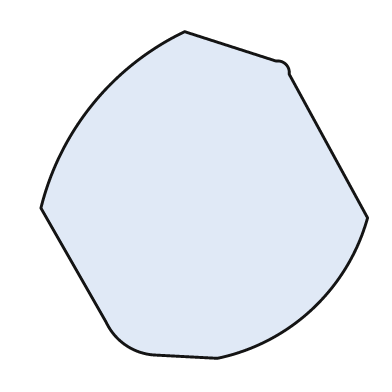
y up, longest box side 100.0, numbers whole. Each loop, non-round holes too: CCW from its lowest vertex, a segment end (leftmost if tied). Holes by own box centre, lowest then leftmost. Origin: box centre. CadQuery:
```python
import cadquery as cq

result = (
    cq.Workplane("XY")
    .moveTo(4.0, -50.0)
    .threePointArc((33.0, -35.0), (50.0, -7.0))
    .lineTo(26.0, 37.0)
    .threePointArc((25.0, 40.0), (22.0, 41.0))
    .lineTo(-6.0, 50.0)
    .threePointArc((-34.0, 28.0), (-50.0, -4.0))
    .lineTo(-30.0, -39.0)
    .threePointArc((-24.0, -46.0), (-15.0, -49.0))
    .close()
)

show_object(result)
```